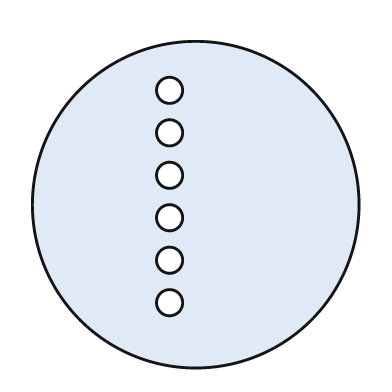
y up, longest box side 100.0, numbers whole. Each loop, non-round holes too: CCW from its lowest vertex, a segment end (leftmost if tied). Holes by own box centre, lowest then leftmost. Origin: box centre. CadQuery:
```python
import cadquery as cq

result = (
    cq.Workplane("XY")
    .moveTo(0.0, 0.0)
    .circle(50.0)
    .moveTo(-8.0, -30.0)
    .circle(4.0)
    .moveTo(-8.0, -17.0)
    .circle(4.0)
    .moveTo(-8.0, -4.0)
    .circle(4.0)
    .moveTo(-8.0, 9.0)
    .circle(4.0)
    .moveTo(-8.0, 22.0)
    .circle(4.0)
    .moveTo(-8.0, 35.0)
    .circle(4.0)
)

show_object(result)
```